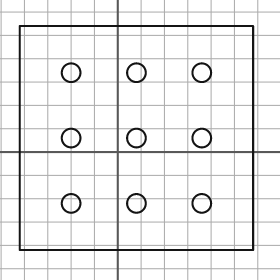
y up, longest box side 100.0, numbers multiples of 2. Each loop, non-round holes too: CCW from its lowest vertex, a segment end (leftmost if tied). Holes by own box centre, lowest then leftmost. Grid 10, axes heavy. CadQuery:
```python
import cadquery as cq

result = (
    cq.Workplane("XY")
    .moveTo(-42.0, -42.0)
    .lineTo(58.0, -42.0)
    .lineTo(58.0, 54.0)
    .lineTo(-42.0, 54.0)
    .close()
    .moveTo(-20.0, -22.0)
    .circle(4.0)
    .moveTo(8.0, -22.0)
    .circle(4.0)
    .moveTo(36.0, -22.0)
    .circle(4.0)
    .moveTo(-20.0, 6.0)
    .circle(4.0)
    .moveTo(8.0, 6.0)
    .circle(4.0)
    .moveTo(36.0, 6.0)
    .circle(4.0)
    .moveTo(-20.0, 34.0)
    .circle(4.0)
    .moveTo(8.0, 34.0)
    .circle(4.0)
    .moveTo(36.0, 34.0)
    .circle(4.0)
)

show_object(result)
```